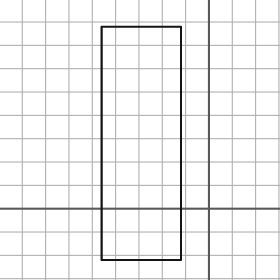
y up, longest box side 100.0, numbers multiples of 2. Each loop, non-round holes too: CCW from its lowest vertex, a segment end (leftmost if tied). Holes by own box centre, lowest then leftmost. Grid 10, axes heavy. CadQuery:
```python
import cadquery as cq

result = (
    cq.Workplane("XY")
    .moveTo(-46.0, -22.0)
    .lineTo(-12.0, -22.0)
    .lineTo(-12.0, 78.0)
    .lineTo(-46.0, 78.0)
    .close()
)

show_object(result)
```